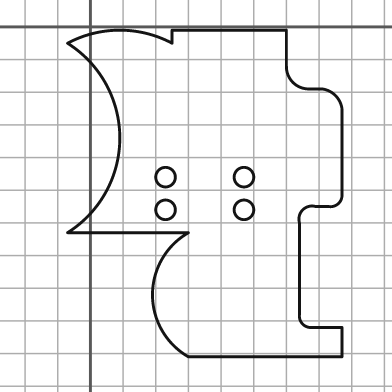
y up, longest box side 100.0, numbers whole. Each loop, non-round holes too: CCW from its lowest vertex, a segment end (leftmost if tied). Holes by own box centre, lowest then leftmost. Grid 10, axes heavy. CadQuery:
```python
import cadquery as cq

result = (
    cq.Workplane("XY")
    .moveTo(30.0, -101.0)
    .lineTo(77.0, -101.0)
    .lineTo(77.0, -92.0)
    .lineTo(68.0, -92.0)
    .threePointArc((65.0, -91.0), (64.0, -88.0))
    .lineTo(64.0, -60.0)
    .threePointArc((65.0, -56.0), (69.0, -55.0))
    .lineTo(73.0, -55.0)
    .threePointArc((76.0, -54.0), (77.0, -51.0))
    .lineTo(77.0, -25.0)
    .threePointArc((75.0, -21.0), (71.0, -19.0))
    .lineTo(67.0, -19.0)
    .threePointArc((62.0, -17.0), (60.0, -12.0))
    .lineTo(60.0, -1.0)
    .lineTo(25.0, -1.0)
    .lineTo(25.0, -5.0)
    .threePointArc((9.0, -1.0), (-7.0, -5.0))
    .threePointArc((9.0, -34.0), (-7.0, -63.0))
    .lineTo(30.0, -63.0)
    .threePointArc((19.0, -82.0), (30.0, -101.0))
    .close()
    .moveTo(23.0, -56.0)
    .circle(3.0)
    .moveTo(47.0, -56.0)
    .circle(3.0)
    .moveTo(23.0, -46.0)
    .circle(3.0)
    .moveTo(47.0, -46.0)
    .circle(3.0)
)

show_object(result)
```